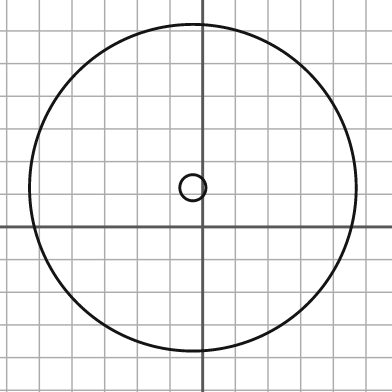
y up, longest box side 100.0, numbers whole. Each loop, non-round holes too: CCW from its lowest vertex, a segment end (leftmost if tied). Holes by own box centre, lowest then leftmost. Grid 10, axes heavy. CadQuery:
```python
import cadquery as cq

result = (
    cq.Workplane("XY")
    .moveTo(-3.0, 12.0)
    .circle(50.0)
    .moveTo(-3.0, 12.0)
    .circle(4.0)
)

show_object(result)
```